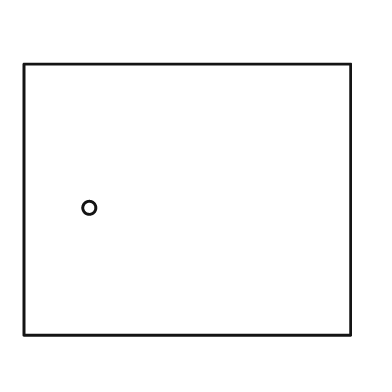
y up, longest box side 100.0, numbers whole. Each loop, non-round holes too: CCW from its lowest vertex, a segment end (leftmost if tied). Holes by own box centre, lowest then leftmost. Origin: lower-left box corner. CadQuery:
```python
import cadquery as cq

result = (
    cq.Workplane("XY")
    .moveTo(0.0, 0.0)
    .lineTo(100.0, 0.0)
    .lineTo(100.0, 83.0)
    .lineTo(0.0, 83.0)
    .close()
    .moveTo(20.0, 39.0)
    .circle(2.0)
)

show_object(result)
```